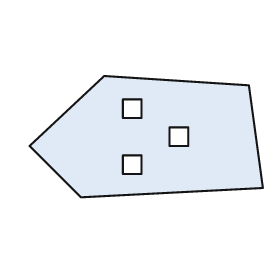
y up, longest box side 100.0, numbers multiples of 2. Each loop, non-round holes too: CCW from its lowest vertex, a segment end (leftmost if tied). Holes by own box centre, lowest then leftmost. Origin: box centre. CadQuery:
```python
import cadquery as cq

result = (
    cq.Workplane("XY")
    .moveTo(-28.0, -26.0)
    .lineTo(50.0, -22.0)
    .lineTo(44.0, 22.0)
    .lineTo(-18.0, 26.0)
    .lineTo(-50.0, -4.0)
    .close()
    .moveTo(-10.0, -16.0)
    .lineTo(-2.0, -16.0)
    .lineTo(-2.0, -8.0)
    .lineTo(-10.0, -8.0)
    .close()
    .moveTo(10.0, -4.0)
    .lineTo(18.0, -4.0)
    .lineTo(18.0, 4.0)
    .lineTo(10.0, 4.0)
    .close()
    .moveTo(-10.0, 8.0)
    .lineTo(-2.0, 8.0)
    .lineTo(-2.0, 16.0)
    .lineTo(-10.0, 16.0)
    .close()
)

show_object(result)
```